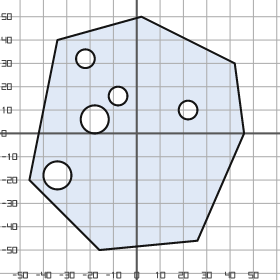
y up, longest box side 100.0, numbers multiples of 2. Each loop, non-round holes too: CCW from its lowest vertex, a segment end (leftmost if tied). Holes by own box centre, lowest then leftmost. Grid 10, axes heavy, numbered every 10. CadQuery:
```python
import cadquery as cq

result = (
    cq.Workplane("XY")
    .moveTo(-16.0, -50.0)
    .lineTo(26.0, -46.0)
    .lineTo(46.0, 0.0)
    .lineTo(42.0, 30.0)
    .lineTo(2.0, 50.0)
    .lineTo(-34.0, 40.0)
    .lineTo(-46.0, -20.0)
    .close()
    .moveTo(-34.0, -18.0)
    .circle(6.0)
    .moveTo(-18.0, 6.0)
    .circle(6.0)
    .moveTo(22.0, 10.0)
    .circle(4.0)
    .moveTo(-8.0, 16.0)
    .circle(4.0)
    .moveTo(-22.0, 32.0)
    .circle(4.0)
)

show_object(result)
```